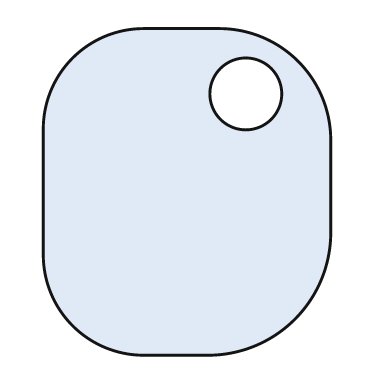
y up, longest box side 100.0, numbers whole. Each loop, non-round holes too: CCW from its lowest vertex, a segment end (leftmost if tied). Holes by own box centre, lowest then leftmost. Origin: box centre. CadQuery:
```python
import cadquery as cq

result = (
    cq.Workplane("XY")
    .moveTo(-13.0, -50.0)
    .lineTo(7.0, -50.0)
    .threePointArc((33.0, -39.0), (44.0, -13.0))
    .lineTo(44.0, 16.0)
    .threePointArc((34.0, 40.0), (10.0, 50.0))
    .lineTo(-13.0, 50.0)
    .threePointArc((-35.0, 41.0), (-44.0, 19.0))
    .lineTo(-44.0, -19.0)
    .threePointArc((-35.0, -41.0), (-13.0, -50.0))
    .close()
    .moveTo(18.0, 30.0)
    .circle(11.0)
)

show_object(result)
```